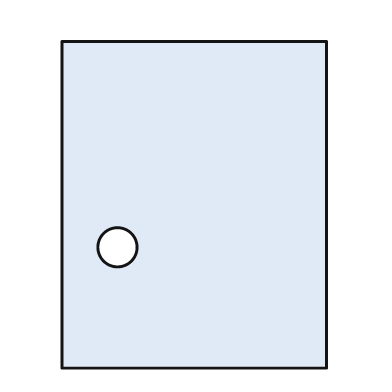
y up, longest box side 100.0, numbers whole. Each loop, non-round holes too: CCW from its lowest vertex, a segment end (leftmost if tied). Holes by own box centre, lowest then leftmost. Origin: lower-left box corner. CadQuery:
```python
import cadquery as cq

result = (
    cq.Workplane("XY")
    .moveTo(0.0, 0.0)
    .lineTo(81.0, 0.0)
    .lineTo(81.0, 100.0)
    .lineTo(0.0, 100.0)
    .close()
    .moveTo(17.0, 37.0)
    .circle(6.0)
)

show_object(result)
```